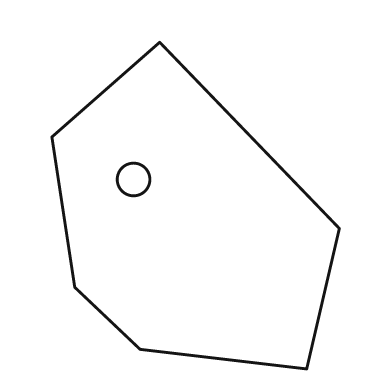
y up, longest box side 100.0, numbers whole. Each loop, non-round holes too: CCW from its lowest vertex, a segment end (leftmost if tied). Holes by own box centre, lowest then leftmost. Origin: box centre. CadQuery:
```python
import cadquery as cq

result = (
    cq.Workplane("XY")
    .moveTo(34.0, -50.0)
    .lineTo(44.0, -7.0)
    .lineTo(-11.0, 50.0)
    .lineTo(-44.0, 21.0)
    .lineTo(-37.0, -25.0)
    .lineTo(-17.0, -44.0)
    .close()
    .moveTo(-19.0, 8.0)
    .circle(5.0)
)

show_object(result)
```